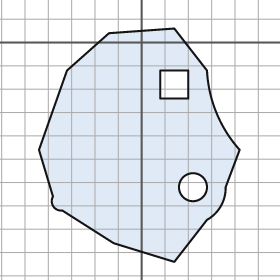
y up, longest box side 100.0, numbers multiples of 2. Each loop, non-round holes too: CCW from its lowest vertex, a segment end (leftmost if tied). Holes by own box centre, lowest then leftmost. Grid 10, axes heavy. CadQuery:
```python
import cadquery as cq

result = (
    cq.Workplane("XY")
    .moveTo(14.0, -94.0)
    .lineTo(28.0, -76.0)
    .threePointArc((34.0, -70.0), (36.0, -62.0))
    .lineTo(42.0, -46.0)
    .threePointArc((32.0, -30.0), (28.0, -12.0))
    .lineTo(14.0, 6.0)
    .lineTo(-14.0, 4.0)
    .lineTo(-32.0, -12.0)
    .lineTo(-44.0, -46.0)
    .lineTo(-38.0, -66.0)
    .threePointArc((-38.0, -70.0), (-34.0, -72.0))
    .lineTo(-12.0, -86.0)
    .close()
    .moveTo(22.0, -62.0)
    .circle(6.0)
    .moveTo(8.0, -24.0)
    .lineTo(20.0, -24.0)
    .lineTo(20.0, -12.0)
    .lineTo(8.0, -12.0)
    .close()
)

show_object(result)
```